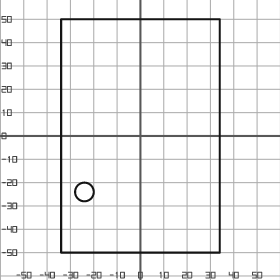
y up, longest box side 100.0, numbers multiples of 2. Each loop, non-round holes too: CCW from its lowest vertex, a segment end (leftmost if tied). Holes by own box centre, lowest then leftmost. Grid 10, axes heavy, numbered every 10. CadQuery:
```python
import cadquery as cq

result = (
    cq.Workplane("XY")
    .moveTo(-34.0, -50.0)
    .lineTo(34.0, -50.0)
    .lineTo(34.0, 50.0)
    .lineTo(-34.0, 50.0)
    .close()
    .moveTo(-24.0, -24.0)
    .circle(4.0)
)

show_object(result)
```